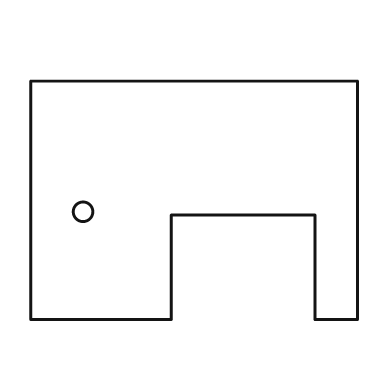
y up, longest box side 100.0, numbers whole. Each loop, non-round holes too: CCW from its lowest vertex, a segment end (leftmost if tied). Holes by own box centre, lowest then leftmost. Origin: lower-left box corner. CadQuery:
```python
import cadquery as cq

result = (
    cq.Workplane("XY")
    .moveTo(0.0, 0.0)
    .lineTo(43.0, 0.0)
    .lineTo(43.0, 32.0)
    .lineTo(87.0, 32.0)
    .lineTo(87.0, 0.0)
    .lineTo(100.0, 0.0)
    .lineTo(100.0, 73.0)
    .lineTo(0.0, 73.0)
    .close()
    .moveTo(16.0, 33.0)
    .circle(3.0)
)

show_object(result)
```